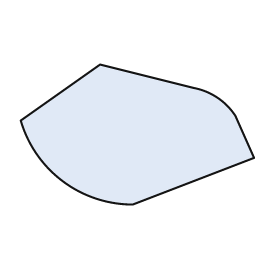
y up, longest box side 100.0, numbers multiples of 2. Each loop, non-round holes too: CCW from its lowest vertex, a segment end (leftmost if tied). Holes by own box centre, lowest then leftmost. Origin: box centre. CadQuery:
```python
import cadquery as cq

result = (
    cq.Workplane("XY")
    .moveTo(-2.0, -30.0)
    .lineTo(50.0, -10.0)
    .lineTo(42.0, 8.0)
    .threePointArc((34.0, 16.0), (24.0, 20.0))
    .lineTo(-16.0, 30.0)
    .lineTo(-50.0, 6.0)
    .threePointArc((-32.0, -20.0), (-2.0, -30.0))
    .close()
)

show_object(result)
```